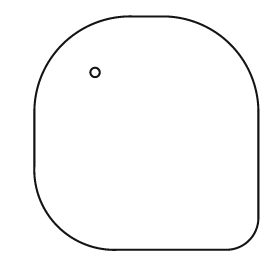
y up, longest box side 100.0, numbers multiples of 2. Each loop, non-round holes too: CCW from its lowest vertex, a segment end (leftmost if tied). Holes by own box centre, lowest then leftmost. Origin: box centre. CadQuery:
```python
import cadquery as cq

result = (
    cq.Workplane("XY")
    .moveTo(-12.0, -50.0)
    .lineTo(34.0, -50.0)
    .threePointArc((44.0, -46.0), (48.0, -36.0))
    .lineTo(48.0, 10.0)
    .threePointArc((36.0, 38.0), (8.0, 50.0))
    .lineTo(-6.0, 50.0)
    .threePointArc((-36.0, 38.0), (-48.0, 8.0))
    .lineTo(-48.0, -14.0)
    .threePointArc((-38.0, -40.0), (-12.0, -50.0))
    .close()
    .moveTo(-22.0, 26.0)
    .circle(2.0)
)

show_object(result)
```